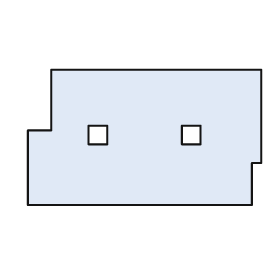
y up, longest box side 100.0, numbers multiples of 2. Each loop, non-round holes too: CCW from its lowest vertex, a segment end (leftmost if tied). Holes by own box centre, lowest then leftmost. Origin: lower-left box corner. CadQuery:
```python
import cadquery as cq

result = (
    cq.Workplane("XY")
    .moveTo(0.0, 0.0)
    .lineTo(96.0, 0.0)
    .lineTo(96.0, 18.0)
    .lineTo(100.0, 18.0)
    .lineTo(100.0, 58.0)
    .lineTo(10.0, 58.0)
    .lineTo(10.0, 32.0)
    .lineTo(0.0, 32.0)
    .close()
    .moveTo(26.0, 26.0)
    .lineTo(34.0, 26.0)
    .lineTo(34.0, 34.0)
    .lineTo(26.0, 34.0)
    .close()
    .moveTo(66.0, 26.0)
    .lineTo(74.0, 26.0)
    .lineTo(74.0, 34.0)
    .lineTo(66.0, 34.0)
    .close()
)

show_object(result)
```